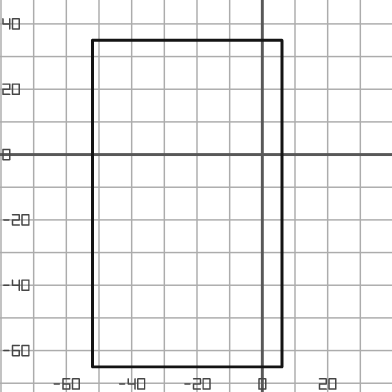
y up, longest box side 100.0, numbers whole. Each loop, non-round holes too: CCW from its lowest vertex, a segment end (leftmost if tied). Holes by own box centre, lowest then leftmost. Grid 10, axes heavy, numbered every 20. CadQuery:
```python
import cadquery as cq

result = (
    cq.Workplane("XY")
    .moveTo(-52.0, -65.0)
    .lineTo(6.0, -65.0)
    .lineTo(6.0, 35.0)
    .lineTo(-52.0, 35.0)
    .close()
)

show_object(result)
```